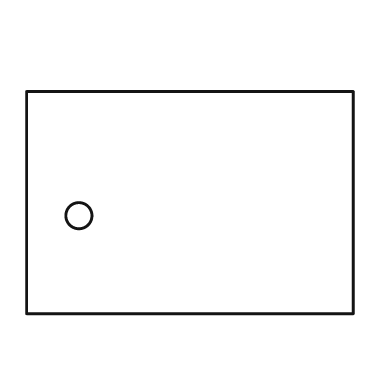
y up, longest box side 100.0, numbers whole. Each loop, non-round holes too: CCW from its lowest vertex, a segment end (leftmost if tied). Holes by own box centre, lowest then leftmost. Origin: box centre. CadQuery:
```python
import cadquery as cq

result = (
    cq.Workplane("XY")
    .moveTo(-50.0, -34.0)
    .lineTo(50.0, -34.0)
    .lineTo(50.0, 34.0)
    .lineTo(-50.0, 34.0)
    .close()
    .moveTo(-34.0, -4.0)
    .circle(4.0)
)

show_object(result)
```